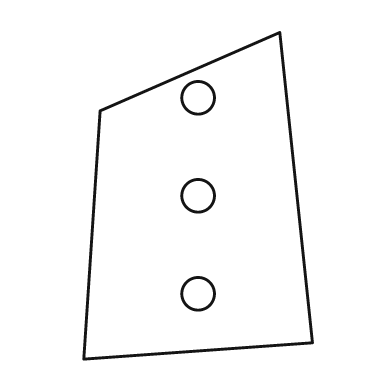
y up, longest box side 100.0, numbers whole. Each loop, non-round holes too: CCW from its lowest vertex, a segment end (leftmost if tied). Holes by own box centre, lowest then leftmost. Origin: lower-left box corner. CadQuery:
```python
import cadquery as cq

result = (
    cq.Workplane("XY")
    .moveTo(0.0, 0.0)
    .lineTo(70.0, 5.0)
    .lineTo(60.0, 100.0)
    .lineTo(5.0, 76.0)
    .close()
    .moveTo(35.0, 20.0)
    .circle(5.0)
    .moveTo(35.0, 50.0)
    .circle(5.0)
    .moveTo(35.0, 80.0)
    .circle(5.0)
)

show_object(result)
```